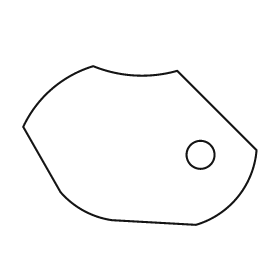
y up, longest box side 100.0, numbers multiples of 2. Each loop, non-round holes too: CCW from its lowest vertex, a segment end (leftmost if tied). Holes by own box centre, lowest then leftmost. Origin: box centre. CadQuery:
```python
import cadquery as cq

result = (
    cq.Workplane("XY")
    .moveTo(24.0, -34.0)
    .threePointArc((42.0, -22.0), (50.0, -2.0))
    .lineTo(16.0, 32.0)
    .threePointArc((-2.0, 30.0), (-20.0, 34.0))
    .threePointArc((-38.0, 24.0), (-50.0, 8.0))
    .lineTo(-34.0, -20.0)
    .threePointArc((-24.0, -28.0), (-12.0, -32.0))
    .close()
    .moveTo(26.0, -4.0)
    .circle(6.0)
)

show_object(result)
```